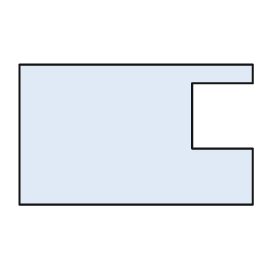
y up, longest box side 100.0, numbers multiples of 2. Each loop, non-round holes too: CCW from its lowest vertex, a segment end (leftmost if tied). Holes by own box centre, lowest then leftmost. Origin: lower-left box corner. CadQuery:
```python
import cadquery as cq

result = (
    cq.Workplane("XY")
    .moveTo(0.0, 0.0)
    .lineTo(100.0, 0.0)
    .lineTo(100.0, 24.0)
    .lineTo(74.0, 24.0)
    .lineTo(74.0, 52.0)
    .lineTo(100.0, 52.0)
    .lineTo(100.0, 60.0)
    .lineTo(0.0, 60.0)
    .close()
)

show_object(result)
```